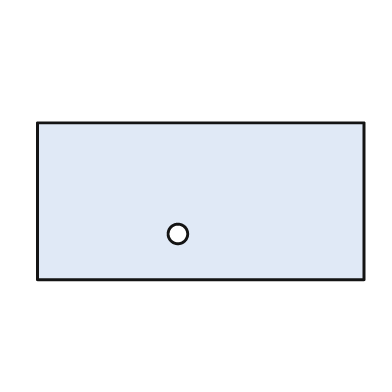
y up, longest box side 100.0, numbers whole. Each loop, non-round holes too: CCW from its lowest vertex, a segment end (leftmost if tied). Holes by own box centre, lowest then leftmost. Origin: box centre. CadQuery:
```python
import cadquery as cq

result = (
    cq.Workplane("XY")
    .moveTo(-50.0, -24.0)
    .lineTo(50.0, -24.0)
    .lineTo(50.0, 24.0)
    .lineTo(-50.0, 24.0)
    .close()
    .moveTo(-7.0, -10.0)
    .circle(3.0)
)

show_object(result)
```